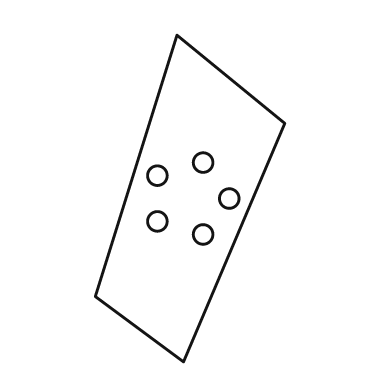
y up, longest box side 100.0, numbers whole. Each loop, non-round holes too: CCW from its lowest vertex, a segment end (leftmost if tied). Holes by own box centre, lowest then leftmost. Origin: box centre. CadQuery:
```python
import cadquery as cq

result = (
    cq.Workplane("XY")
    .moveTo(-2.0, -50.0)
    .lineTo(29.0, 23.0)
    .lineTo(-4.0, 50.0)
    .lineTo(-29.0, -30.0)
    .close()
    .moveTo(4.0, -11.0)
    .circle(3.0)
    .moveTo(-10.0, -7.0)
    .circle(3.0)
    .moveTo(12.0, 0.0)
    .circle(3.0)
    .moveTo(-10.0, 7.0)
    .circle(3.0)
    .moveTo(4.0, 11.0)
    .circle(3.0)
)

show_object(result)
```